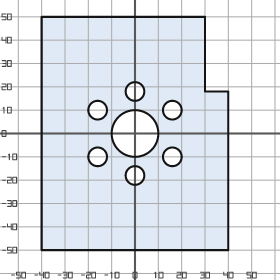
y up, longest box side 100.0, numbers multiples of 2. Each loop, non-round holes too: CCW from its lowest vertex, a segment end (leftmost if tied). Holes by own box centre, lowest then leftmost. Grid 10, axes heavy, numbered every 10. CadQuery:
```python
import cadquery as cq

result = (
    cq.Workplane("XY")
    .moveTo(-40.0, -50.0)
    .lineTo(40.0, -50.0)
    .lineTo(40.0, 18.0)
    .lineTo(30.0, 18.0)
    .lineTo(30.0, 50.0)
    .lineTo(-40.0, 50.0)
    .close()
    .moveTo(0.0, -18.0)
    .circle(4.0)
    .moveTo(-16.0, -10.0)
    .circle(4.0)
    .moveTo(16.0, -10.0)
    .circle(4.0)
    .moveTo(0.0, 0.0)
    .circle(10.0)
    .moveTo(-16.0, 10.0)
    .circle(4.0)
    .moveTo(16.0, 10.0)
    .circle(4.0)
    .moveTo(0.0, 18.0)
    .circle(4.0)
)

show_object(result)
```